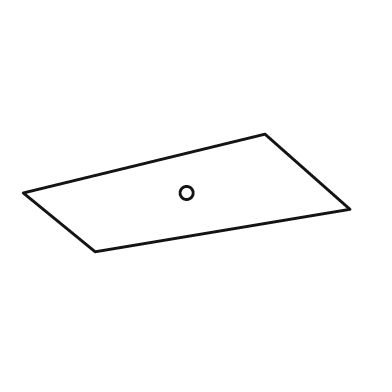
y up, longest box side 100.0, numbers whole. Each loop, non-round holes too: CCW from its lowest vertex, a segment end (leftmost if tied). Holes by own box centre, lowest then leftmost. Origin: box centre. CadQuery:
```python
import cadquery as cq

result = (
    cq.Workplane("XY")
    .moveTo(-28.0, -18.0)
    .lineTo(50.0, -5.0)
    .lineTo(24.0, 18.0)
    .lineTo(-50.0, 0.0)
    .close()
    .moveTo(0.0, 0.0)
    .circle(2.0)
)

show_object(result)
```